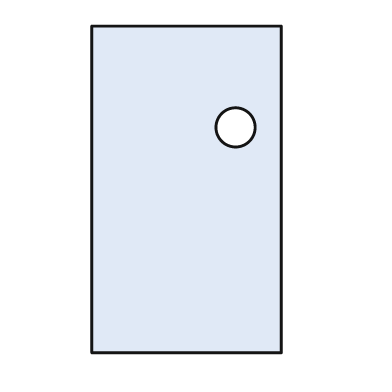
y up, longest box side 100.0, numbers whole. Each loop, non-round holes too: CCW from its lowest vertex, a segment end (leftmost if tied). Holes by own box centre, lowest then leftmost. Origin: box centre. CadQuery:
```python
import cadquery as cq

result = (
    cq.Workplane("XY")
    .moveTo(-29.0, -50.0)
    .lineTo(29.0, -50.0)
    .lineTo(29.0, 50.0)
    .lineTo(-29.0, 50.0)
    .close()
    .moveTo(15.0, 19.0)
    .circle(6.0)
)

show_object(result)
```